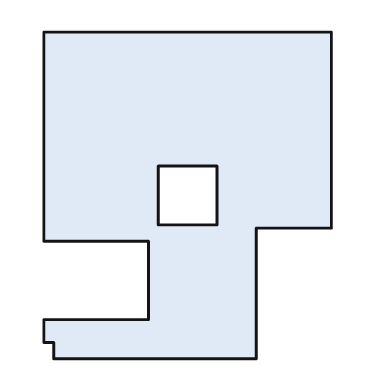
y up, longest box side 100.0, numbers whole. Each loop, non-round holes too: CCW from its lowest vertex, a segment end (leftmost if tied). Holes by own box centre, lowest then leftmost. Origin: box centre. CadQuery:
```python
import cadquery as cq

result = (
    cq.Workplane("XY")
    .moveTo(-41.0, -50.0)
    .lineTo(21.0, -50.0)
    .lineTo(21.0, -10.0)
    .lineTo(44.0, -10.0)
    .lineTo(44.0, 50.0)
    .lineTo(-44.0, 50.0)
    .lineTo(-44.0, -14.0)
    .lineTo(-12.0, -14.0)
    .lineTo(-12.0, -38.0)
    .lineTo(-44.0, -38.0)
    .lineTo(-44.0, -45.0)
    .lineTo(-41.0, -45.0)
    .close()
    .moveTo(-9.0, -9.0)
    .lineTo(9.0, -9.0)
    .lineTo(9.0, 9.0)
    .lineTo(-9.0, 9.0)
    .close()
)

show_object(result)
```